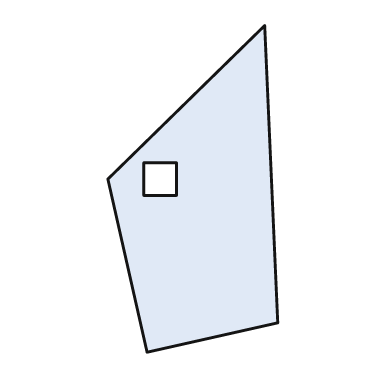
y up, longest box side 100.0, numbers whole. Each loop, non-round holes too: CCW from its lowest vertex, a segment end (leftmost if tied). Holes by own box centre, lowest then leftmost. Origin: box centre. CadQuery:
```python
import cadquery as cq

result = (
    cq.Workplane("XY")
    .moveTo(-14.0, -50.0)
    .lineTo(26.0, -41.0)
    .lineTo(22.0, 50.0)
    .lineTo(-26.0, 3.0)
    .close()
    .moveTo(-15.0, -2.0)
    .lineTo(-5.0, -2.0)
    .lineTo(-5.0, 8.0)
    .lineTo(-15.0, 8.0)
    .close()
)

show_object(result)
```